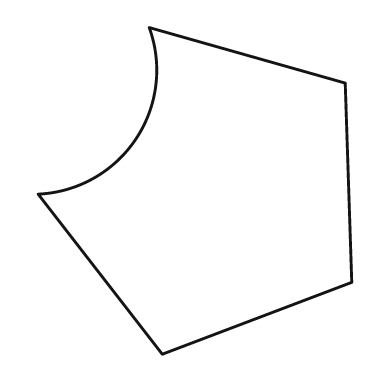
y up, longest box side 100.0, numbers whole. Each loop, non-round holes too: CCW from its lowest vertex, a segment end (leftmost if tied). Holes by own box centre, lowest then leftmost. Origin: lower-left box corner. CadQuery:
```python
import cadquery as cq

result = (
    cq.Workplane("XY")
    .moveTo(38.0, 0.0)
    .lineTo(96.0, 22.0)
    .lineTo(94.0, 83.0)
    .lineTo(34.0, 100.0)
    .threePointArc((30.0, 66.0), (0.0, 49.0))
    .close()
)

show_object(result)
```